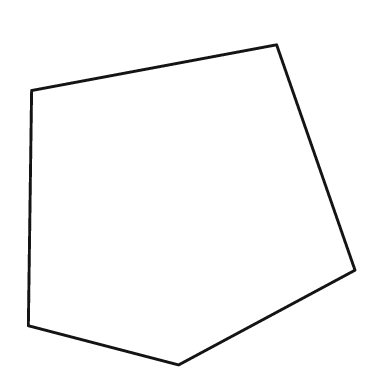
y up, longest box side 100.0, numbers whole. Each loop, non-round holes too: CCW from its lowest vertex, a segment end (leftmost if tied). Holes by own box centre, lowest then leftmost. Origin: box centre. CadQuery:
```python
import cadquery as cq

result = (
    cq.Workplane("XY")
    .moveTo(-4.0, -49.0)
    .lineTo(50.0, -20.0)
    .lineTo(26.0, 49.0)
    .lineTo(-49.0, 35.0)
    .lineTo(-50.0, -37.0)
    .close()
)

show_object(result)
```